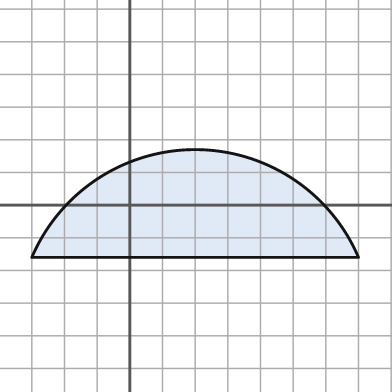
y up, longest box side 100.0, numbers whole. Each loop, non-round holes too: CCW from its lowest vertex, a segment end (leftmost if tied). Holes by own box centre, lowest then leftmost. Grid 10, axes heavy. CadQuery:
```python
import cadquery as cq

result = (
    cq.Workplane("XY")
    .moveTo(-30.0, -16.0)
    .lineTo(70.0, -16.0)
    .threePointArc((20.0, 17.0), (-30.0, -16.0))
    .close()
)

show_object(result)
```